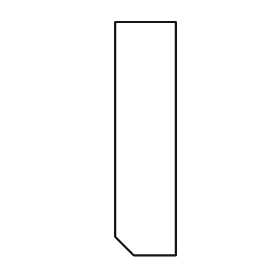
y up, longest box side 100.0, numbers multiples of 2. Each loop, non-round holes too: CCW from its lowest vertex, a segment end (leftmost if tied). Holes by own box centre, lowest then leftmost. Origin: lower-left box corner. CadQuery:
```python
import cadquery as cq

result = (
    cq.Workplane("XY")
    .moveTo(8.0, 0.0)
    .lineTo(26.0, 0.0)
    .lineTo(26.0, 100.0)
    .lineTo(0.0, 100.0)
    .lineTo(0.0, 8.0)
    .close()
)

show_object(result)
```